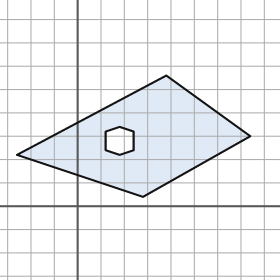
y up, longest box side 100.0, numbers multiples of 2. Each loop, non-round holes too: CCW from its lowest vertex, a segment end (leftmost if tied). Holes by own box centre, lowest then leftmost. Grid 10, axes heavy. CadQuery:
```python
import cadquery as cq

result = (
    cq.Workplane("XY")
    .moveTo(28.0, 4.0)
    .lineTo(74.0, 30.0)
    .lineTo(38.0, 56.0)
    .lineTo(-26.0, 22.0)
    .close()
    .moveTo(18.0, 22.0)
    .lineTo(24.0, 24.0)
    .lineTo(24.0, 32.0)
    .lineTo(18.0, 34.0)
    .lineTo(12.0, 32.0)
    .lineTo(12.0, 24.0)
    .close()
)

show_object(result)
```